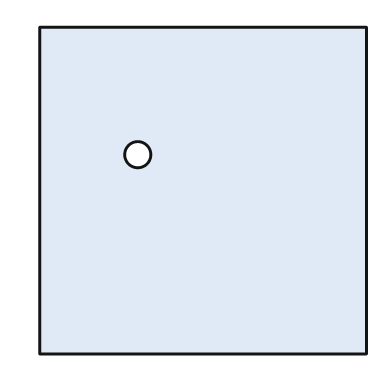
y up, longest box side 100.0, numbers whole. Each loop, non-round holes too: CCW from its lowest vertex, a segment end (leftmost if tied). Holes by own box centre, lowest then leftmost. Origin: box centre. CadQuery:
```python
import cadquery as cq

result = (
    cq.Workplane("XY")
    .moveTo(-50.0, -50.0)
    .lineTo(50.0, -50.0)
    .lineTo(50.0, 50.0)
    .lineTo(-50.0, 50.0)
    .close()
    .moveTo(-20.0, 11.0)
    .circle(4.0)
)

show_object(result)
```